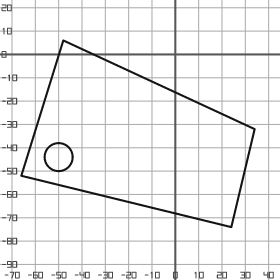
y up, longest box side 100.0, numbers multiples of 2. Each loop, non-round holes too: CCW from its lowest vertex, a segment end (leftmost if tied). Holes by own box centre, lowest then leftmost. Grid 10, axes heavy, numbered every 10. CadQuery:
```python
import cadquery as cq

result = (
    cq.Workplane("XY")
    .moveTo(24.0, -74.0)
    .lineTo(34.0, -32.0)
    .lineTo(-48.0, 6.0)
    .lineTo(-66.0, -52.0)
    .close()
    .moveTo(-50.0, -44.0)
    .circle(6.0)
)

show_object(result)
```